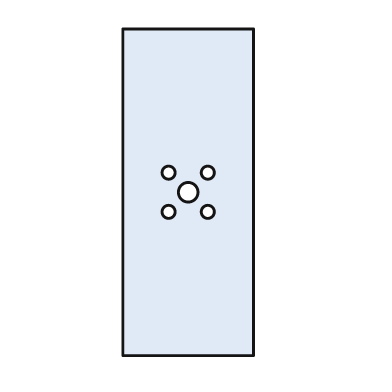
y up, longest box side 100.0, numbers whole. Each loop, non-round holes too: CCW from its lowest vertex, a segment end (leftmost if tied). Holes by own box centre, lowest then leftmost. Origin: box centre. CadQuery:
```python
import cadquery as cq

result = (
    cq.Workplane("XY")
    .moveTo(-20.0, -50.0)
    .lineTo(20.0, -50.0)
    .lineTo(20.0, 50.0)
    .lineTo(-20.0, 50.0)
    .close()
    .moveTo(-6.0, -6.0)
    .circle(2.0)
    .moveTo(6.0, -6.0)
    .circle(2.0)
    .moveTo(0.0, 0.0)
    .circle(3.0)
    .moveTo(-6.0, 6.0)
    .circle(2.0)
    .moveTo(6.0, 6.0)
    .circle(2.0)
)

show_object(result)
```